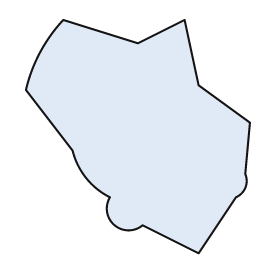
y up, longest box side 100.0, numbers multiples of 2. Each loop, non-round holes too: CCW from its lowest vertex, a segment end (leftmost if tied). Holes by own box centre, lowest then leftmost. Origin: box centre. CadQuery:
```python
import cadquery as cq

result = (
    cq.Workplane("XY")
    .moveTo(26.0, -50.0)
    .lineTo(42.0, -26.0)
    .threePointArc((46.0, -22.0), (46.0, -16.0))
    .lineTo(48.0, 6.0)
    .lineTo(26.0, 22.0)
    .lineTo(20.0, 50.0)
    .lineTo(0.0, 40.0)
    .lineTo(-32.0, 50.0)
    .threePointArc((-42.0, 36.0), (-48.0, 20.0))
    .lineTo(-28.0, -6.0)
    .threePointArc((-22.0, -18.0), (-12.0, -26.0))
    .threePointArc((-10.0, -38.0), (2.0, -38.0))
    .close()
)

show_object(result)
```